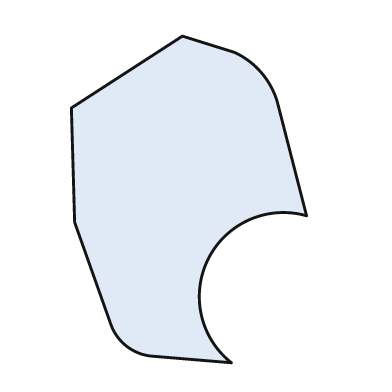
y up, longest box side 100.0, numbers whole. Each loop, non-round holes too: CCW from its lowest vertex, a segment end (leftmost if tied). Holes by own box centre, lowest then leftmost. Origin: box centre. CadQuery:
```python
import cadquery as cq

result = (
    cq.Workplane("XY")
    .moveTo(13.0, -50.0)
    .threePointArc((6.0, -18.0), (36.0, -5.0))
    .lineTo(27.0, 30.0)
    .threePointArc((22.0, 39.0), (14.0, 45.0))
    .lineTo(-2.0, 50.0)
    .lineTo(-36.0, 28.0)
    .lineTo(-35.0, -7.0)
    .lineTo(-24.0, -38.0)
    .threePointArc((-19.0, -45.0), (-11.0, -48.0))
    .close()
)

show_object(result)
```